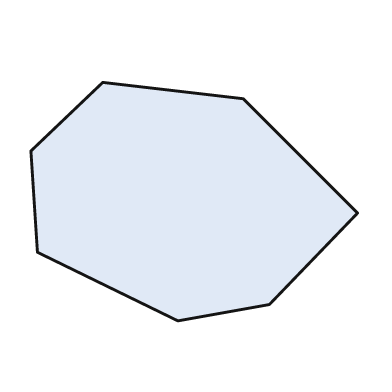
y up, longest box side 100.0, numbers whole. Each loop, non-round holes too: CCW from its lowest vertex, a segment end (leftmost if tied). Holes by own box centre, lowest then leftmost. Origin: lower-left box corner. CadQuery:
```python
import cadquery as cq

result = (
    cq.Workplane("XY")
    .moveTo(45.0, 0.0)
    .lineTo(73.0, 5.0)
    .lineTo(100.0, 33.0)
    .lineTo(65.0, 68.0)
    .lineTo(22.0, 73.0)
    .lineTo(0.0, 52.0)
    .lineTo(2.0, 21.0)
    .close()
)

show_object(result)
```